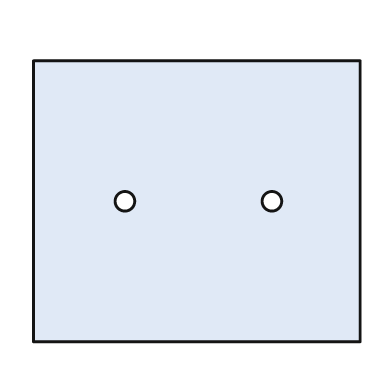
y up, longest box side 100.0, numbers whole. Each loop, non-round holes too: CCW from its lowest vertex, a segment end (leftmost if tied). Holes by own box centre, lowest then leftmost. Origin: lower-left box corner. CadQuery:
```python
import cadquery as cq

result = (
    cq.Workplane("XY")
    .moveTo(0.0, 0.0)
    .lineTo(100.0, 0.0)
    .lineTo(100.0, 86.0)
    .lineTo(0.0, 86.0)
    .close()
    .moveTo(28.0, 43.0)
    .circle(3.0)
    .moveTo(73.0, 43.0)
    .circle(3.0)
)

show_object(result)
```